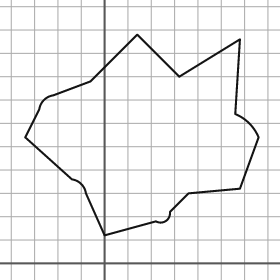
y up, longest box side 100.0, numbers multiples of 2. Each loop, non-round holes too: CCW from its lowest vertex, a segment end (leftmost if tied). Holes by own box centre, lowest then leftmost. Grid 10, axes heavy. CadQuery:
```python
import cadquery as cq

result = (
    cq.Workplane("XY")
    .moveTo(0.0, 12.0)
    .lineTo(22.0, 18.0)
    .threePointArc((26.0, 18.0), (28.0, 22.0))
    .lineTo(36.0, 30.0)
    .lineTo(58.0, 32.0)
    .lineTo(66.0, 54.0)
    .threePointArc((62.0, 60.0), (56.0, 64.0))
    .lineTo(58.0, 96.0)
    .lineTo(32.0, 80.0)
    .lineTo(14.0, 98.0)
    .lineTo(-6.0, 78.0)
    .lineTo(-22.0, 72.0)
    .threePointArc((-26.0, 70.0), (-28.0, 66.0))
    .lineTo(-34.0, 54.0)
    .lineTo(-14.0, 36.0)
    .threePointArc((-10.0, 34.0), (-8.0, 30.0))
    .close()
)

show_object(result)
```